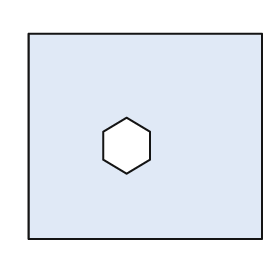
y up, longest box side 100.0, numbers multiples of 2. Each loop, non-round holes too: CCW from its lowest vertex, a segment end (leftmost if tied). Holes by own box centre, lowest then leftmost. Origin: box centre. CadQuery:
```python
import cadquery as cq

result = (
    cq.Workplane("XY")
    .moveTo(-50.0, -44.0)
    .lineTo(50.0, -44.0)
    .lineTo(50.0, 44.0)
    .lineTo(-50.0, 44.0)
    .close()
    .moveTo(-8.0, -16.0)
    .lineTo(2.0, -10.0)
    .lineTo(2.0, 2.0)
    .lineTo(-8.0, 8.0)
    .lineTo(-18.0, 2.0)
    .lineTo(-18.0, -10.0)
    .close()
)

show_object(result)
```